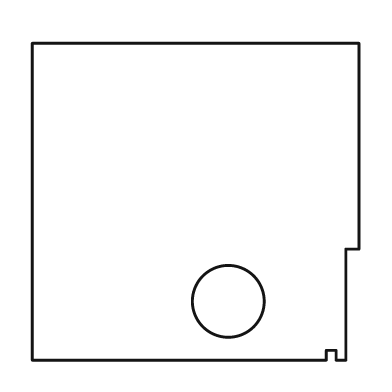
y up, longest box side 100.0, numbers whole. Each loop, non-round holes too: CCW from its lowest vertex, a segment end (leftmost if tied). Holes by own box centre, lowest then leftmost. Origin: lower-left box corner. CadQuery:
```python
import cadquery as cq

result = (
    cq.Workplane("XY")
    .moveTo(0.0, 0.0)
    .lineTo(90.0, 0.0)
    .lineTo(90.0, 3.0)
    .lineTo(93.0, 3.0)
    .lineTo(93.0, 0.0)
    .lineTo(96.0, 0.0)
    .lineTo(96.0, 34.0)
    .lineTo(100.0, 34.0)
    .lineTo(100.0, 97.0)
    .lineTo(0.0, 97.0)
    .close()
    .moveTo(60.0, 18.0)
    .circle(11.0)
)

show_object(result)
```